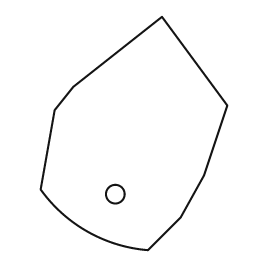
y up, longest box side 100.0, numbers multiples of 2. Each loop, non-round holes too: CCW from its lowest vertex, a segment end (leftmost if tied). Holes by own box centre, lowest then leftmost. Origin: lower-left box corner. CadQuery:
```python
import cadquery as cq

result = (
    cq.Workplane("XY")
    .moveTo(46.0, 0.0)
    .lineTo(60.0, 14.0)
    .lineTo(70.0, 32.0)
    .lineTo(80.0, 62.0)
    .lineTo(52.0, 100.0)
    .lineTo(14.0, 70.0)
    .lineTo(6.0, 60.0)
    .lineTo(0.0, 26.0)
    .threePointArc((20.0, 8.0), (46.0, 0.0))
    .close()
    .moveTo(32.0, 24.0)
    .circle(4.0)
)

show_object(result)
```